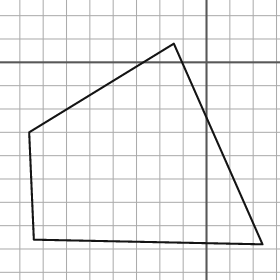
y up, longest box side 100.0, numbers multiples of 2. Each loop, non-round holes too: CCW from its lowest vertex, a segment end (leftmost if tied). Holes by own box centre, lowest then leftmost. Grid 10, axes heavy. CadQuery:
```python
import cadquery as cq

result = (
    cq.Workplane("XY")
    .moveTo(24.0, -78.0)
    .lineTo(-14.0, 8.0)
    .lineTo(-76.0, -30.0)
    .lineTo(-74.0, -76.0)
    .close()
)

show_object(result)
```